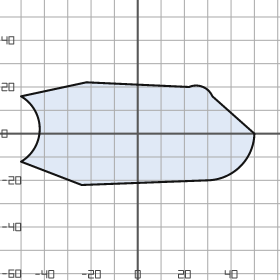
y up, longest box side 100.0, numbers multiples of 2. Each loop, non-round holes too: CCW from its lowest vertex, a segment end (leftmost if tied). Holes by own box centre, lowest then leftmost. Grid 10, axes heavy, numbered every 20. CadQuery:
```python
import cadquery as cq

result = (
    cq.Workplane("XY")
    .moveTo(-24.0, -22.0)
    .lineTo(30.0, -20.0)
    .threePointArc((44.0, -14.0), (50.0, 0.0))
    .lineTo(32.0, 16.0)
    .threePointArc((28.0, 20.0), (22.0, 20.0))
    .lineTo(-22.0, 22.0)
    .lineTo(-50.0, 16.0)
    .threePointArc((-42.0, 2.0), (-50.0, -12.0))
    .close()
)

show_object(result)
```